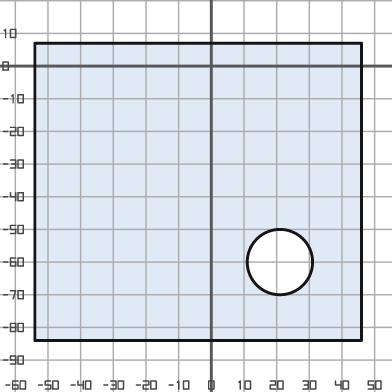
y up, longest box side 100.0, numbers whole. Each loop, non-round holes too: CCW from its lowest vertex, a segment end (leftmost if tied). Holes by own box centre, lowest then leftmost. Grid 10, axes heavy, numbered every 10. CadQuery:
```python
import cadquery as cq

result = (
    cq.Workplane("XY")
    .moveTo(-54.0, -84.0)
    .lineTo(46.0, -84.0)
    .lineTo(46.0, 7.0)
    .lineTo(-54.0, 7.0)
    .close()
    .moveTo(21.0, -60.0)
    .circle(10.0)
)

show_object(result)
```